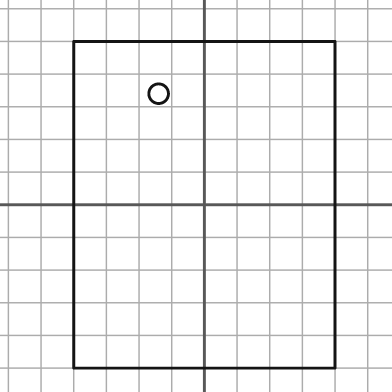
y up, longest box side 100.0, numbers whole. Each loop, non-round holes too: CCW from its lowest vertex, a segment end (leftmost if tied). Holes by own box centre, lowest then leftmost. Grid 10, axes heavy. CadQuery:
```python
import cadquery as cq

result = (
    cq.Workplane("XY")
    .moveTo(-40.0, -50.0)
    .lineTo(40.0, -50.0)
    .lineTo(40.0, 50.0)
    .lineTo(-40.0, 50.0)
    .close()
    .moveTo(-14.0, 34.0)
    .circle(3.0)
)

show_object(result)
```